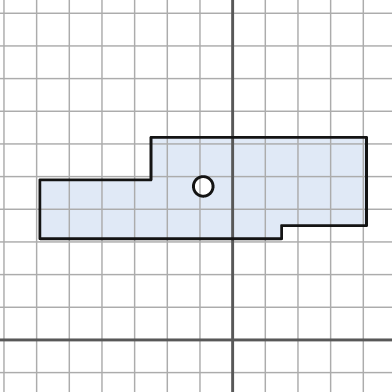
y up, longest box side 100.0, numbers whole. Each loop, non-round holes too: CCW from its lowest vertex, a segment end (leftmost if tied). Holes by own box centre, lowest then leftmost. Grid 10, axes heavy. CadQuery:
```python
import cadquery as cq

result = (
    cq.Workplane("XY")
    .moveTo(-59.0, 31.0)
    .lineTo(15.0, 31.0)
    .lineTo(15.0, 35.0)
    .lineTo(41.0, 35.0)
    .lineTo(41.0, 62.0)
    .lineTo(-25.0, 62.0)
    .lineTo(-25.0, 49.0)
    .lineTo(-59.0, 49.0)
    .close()
    .moveTo(-9.0, 47.0)
    .circle(3.0)
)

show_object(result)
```